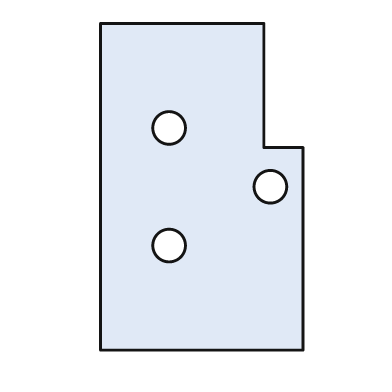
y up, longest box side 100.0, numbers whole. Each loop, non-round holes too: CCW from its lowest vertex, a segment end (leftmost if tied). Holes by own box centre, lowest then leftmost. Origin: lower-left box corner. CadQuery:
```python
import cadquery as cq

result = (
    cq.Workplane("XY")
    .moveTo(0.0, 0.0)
    .lineTo(62.0, 0.0)
    .lineTo(62.0, 62.0)
    .lineTo(50.0, 62.0)
    .lineTo(50.0, 100.0)
    .lineTo(0.0, 100.0)
    .close()
    .moveTo(21.0, 32.0)
    .circle(5.0)
    .moveTo(52.0, 50.0)
    .circle(5.0)
    .moveTo(21.0, 68.0)
    .circle(5.0)
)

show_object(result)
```